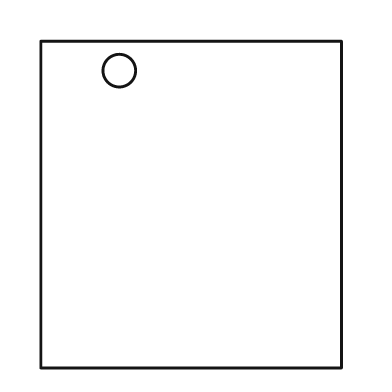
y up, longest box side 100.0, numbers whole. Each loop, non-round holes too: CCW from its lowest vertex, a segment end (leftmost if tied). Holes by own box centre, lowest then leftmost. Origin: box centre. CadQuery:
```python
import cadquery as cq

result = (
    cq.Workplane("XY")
    .moveTo(-46.0, -50.0)
    .lineTo(46.0, -50.0)
    .lineTo(46.0, 50.0)
    .lineTo(-46.0, 50.0)
    .close()
    .moveTo(-22.0, 41.0)
    .circle(5.0)
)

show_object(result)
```